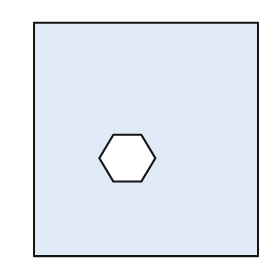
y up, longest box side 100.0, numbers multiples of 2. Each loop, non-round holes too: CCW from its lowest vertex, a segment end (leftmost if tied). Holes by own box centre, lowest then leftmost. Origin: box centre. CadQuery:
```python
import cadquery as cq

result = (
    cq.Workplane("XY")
    .moveTo(-48.0, -50.0)
    .lineTo(48.0, -50.0)
    .lineTo(48.0, 50.0)
    .lineTo(-48.0, 50.0)
    .close()
    .moveTo(-14.0, -18.0)
    .lineTo(-2.0, -18.0)
    .lineTo(4.0, -8.0)
    .lineTo(-2.0, 2.0)
    .lineTo(-14.0, 2.0)
    .lineTo(-20.0, -8.0)
    .close()
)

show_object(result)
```